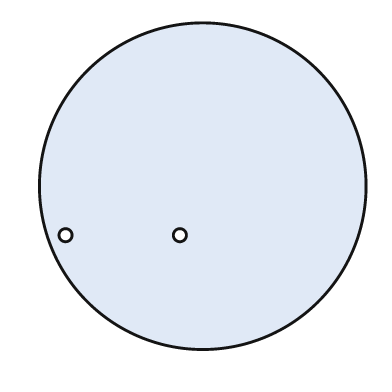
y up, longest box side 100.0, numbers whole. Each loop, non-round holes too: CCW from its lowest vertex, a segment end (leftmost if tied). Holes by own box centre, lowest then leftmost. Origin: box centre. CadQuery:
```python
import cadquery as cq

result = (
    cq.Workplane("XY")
    .moveTo(0.0, 0.0)
    .circle(50.0)
    .moveTo(-42.0, -15.0)
    .circle(2.0)
    .moveTo(-7.0, -15.0)
    .circle(2.0)
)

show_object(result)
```